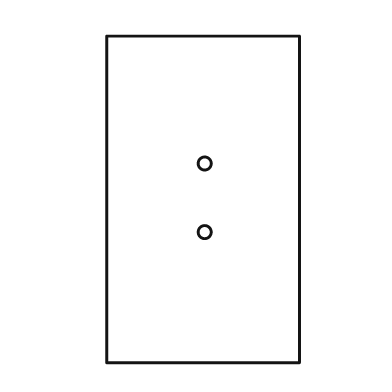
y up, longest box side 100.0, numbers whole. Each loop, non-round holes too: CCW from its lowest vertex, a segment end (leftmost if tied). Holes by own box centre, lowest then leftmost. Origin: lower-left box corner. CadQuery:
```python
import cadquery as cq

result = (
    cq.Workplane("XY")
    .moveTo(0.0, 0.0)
    .lineTo(59.0, 0.0)
    .lineTo(59.0, 100.0)
    .lineTo(0.0, 100.0)
    .close()
    .moveTo(30.0, 40.0)
    .circle(2.0)
    .moveTo(30.0, 61.0)
    .circle(2.0)
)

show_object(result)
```